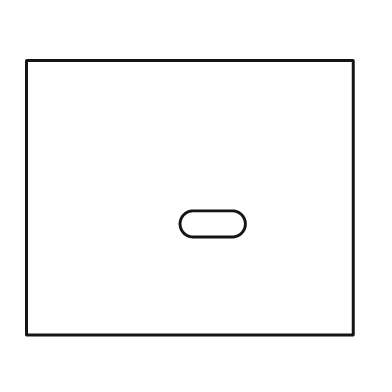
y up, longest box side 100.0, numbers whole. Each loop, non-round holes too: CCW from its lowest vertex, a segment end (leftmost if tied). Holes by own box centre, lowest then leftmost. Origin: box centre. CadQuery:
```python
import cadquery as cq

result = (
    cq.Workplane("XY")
    .moveTo(-50.0, -42.0)
    .lineTo(50.0, -42.0)
    .lineTo(50.0, 42.0)
    .lineTo(-50.0, 42.0)
    .close()
    .moveTo(1.0, -12.0)
    .lineTo(13.0, -12.0)
    .threePointArc((17.0, -8.0), (13.0, -4.0))
    .lineTo(1.0, -4.0)
    .threePointArc((-3.0, -8.0), (1.0, -12.0))
    .close()
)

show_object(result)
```